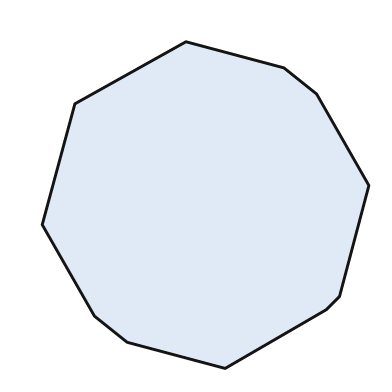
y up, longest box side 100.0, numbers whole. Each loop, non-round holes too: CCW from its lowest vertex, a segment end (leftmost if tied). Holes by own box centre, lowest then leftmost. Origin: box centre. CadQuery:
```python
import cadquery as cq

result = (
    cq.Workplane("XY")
    .moveTo(6.0, -50.0)
    .lineTo(37.0, -32.0)
    .lineTo(41.0, -28.0)
    .lineTo(50.0, 6.0)
    .lineTo(34.0, 34.0)
    .lineTo(24.0, 42.0)
    .lineTo(-6.0, 50.0)
    .lineTo(-40.0, 31.0)
    .lineTo(-50.0, -6.0)
    .lineTo(-34.0, -34.0)
    .lineTo(-24.0, -42.0)
    .close()
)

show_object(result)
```